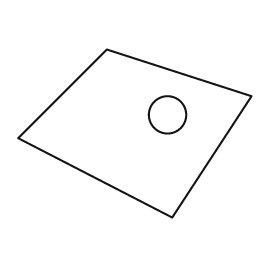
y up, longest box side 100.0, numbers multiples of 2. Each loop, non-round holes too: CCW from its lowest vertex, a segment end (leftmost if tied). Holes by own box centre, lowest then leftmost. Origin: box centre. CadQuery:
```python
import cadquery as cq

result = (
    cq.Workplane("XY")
    .moveTo(16.0, -36.0)
    .lineTo(50.0, 16.0)
    .lineTo(-12.0, 36.0)
    .lineTo(-50.0, -2.0)
    .close()
    .moveTo(14.0, 8.0)
    .circle(8.0)
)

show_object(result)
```